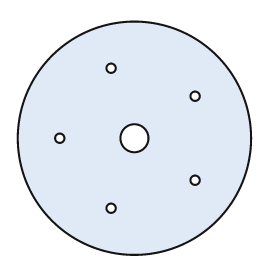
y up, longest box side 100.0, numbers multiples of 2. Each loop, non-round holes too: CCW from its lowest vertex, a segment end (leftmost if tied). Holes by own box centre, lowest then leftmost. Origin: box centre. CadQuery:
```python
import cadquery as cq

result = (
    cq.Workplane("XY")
    .moveTo(0.0, 0.0)
    .circle(50.0)
    .moveTo(-10.0, -30.0)
    .circle(2.0)
    .moveTo(26.0, -18.0)
    .circle(2.0)
    .moveTo(-32.0, 0.0)
    .circle(2.0)
    .moveTo(0.0, 0.0)
    .circle(6.0)
    .moveTo(26.0, 18.0)
    .circle(2.0)
    .moveTo(-10.0, 30.0)
    .circle(2.0)
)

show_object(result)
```